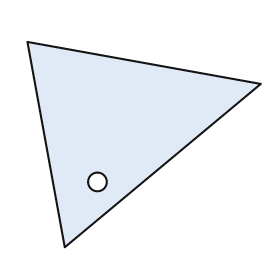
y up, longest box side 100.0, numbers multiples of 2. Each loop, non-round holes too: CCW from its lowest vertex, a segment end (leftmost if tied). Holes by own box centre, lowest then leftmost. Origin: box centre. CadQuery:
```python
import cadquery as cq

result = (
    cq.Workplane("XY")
    .moveTo(-34.0, -44.0)
    .lineTo(50.0, 26.0)
    .lineTo(-50.0, 44.0)
    .close()
    .moveTo(-20.0, -16.0)
    .circle(4.0)
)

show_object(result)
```